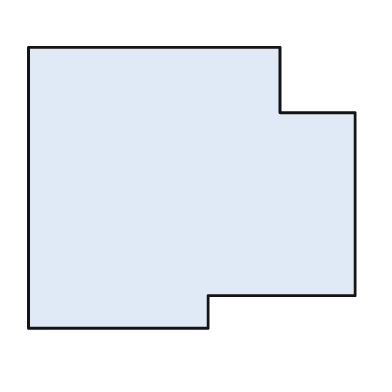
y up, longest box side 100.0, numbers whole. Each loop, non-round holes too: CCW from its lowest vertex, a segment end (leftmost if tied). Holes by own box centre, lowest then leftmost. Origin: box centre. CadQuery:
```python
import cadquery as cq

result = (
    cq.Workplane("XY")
    .moveTo(-50.0, -43.0)
    .lineTo(5.0, -43.0)
    .lineTo(5.0, -33.0)
    .lineTo(50.0, -33.0)
    .lineTo(50.0, 23.0)
    .lineTo(27.0, 23.0)
    .lineTo(27.0, 43.0)
    .lineTo(-50.0, 43.0)
    .close()
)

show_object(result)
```